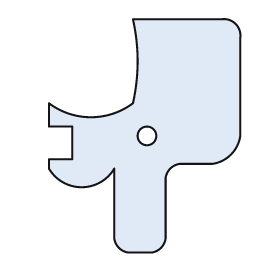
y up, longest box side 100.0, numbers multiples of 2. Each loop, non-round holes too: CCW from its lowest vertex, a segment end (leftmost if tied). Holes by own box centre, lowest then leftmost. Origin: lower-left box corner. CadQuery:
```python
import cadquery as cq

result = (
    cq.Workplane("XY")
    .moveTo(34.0, 0.0)
    .lineTo(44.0, 0.0)
    .threePointArc((48.0, 2.0), (50.0, 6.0))
    .lineTo(50.0, 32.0)
    .threePointArc((52.0, 36.0), (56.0, 38.0))
    .lineTo(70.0, 38.0)
    .threePointArc((78.0, 42.0), (82.0, 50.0))
    .lineTo(82.0, 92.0)
    .threePointArc((80.0, 98.0), (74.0, 100.0))
    .lineTo(36.0, 100.0)
    .threePointArc((38.0, 82.0), (36.0, 64.0))
    .threePointArc((18.0, 58.0), (0.0, 64.0))
    .lineTo(0.0, 54.0)
    .lineTo(10.0, 54.0)
    .lineTo(10.0, 40.0)
    .lineTo(0.0, 40.0)
    .lineTo(0.0, 36.0)
    .threePointArc((14.0, 28.0), (28.0, 36.0))
    .lineTo(28.0, 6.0)
    .threePointArc((30.0, 2.0), (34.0, 0.0))
    .close()
    .moveTo(42.0, 50.0)
    .circle(4.0)
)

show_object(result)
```